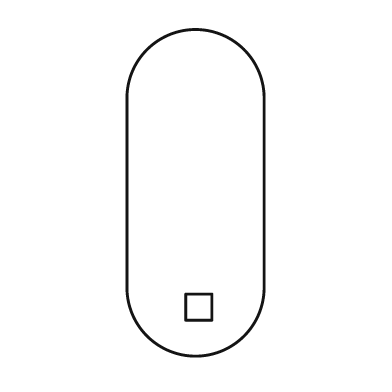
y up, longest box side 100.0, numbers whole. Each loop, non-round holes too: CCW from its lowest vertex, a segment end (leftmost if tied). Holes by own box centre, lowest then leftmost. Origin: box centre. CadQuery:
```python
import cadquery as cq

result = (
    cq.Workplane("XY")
    .moveTo(-21.0, -29.0)
    .threePointArc((0.0, -50.0), (21.0, -29.0))
    .lineTo(21.0, 29.0)
    .threePointArc((0.0, 50.0), (-21.0, 29.0))
    .close()
    .moveTo(-3.0, -39.0)
    .lineTo(5.0, -39.0)
    .lineTo(5.0, -31.0)
    .lineTo(-3.0, -31.0)
    .close()
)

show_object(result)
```